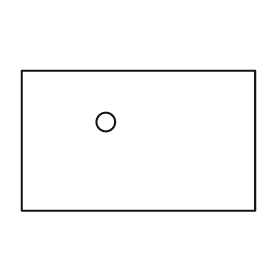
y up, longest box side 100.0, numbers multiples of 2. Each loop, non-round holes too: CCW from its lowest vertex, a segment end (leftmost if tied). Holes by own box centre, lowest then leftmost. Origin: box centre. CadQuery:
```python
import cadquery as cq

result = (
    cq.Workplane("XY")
    .moveTo(-50.0, -30.0)
    .lineTo(50.0, -30.0)
    .lineTo(50.0, 30.0)
    .lineTo(-50.0, 30.0)
    .close()
    .moveTo(-14.0, 8.0)
    .circle(4.0)
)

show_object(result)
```